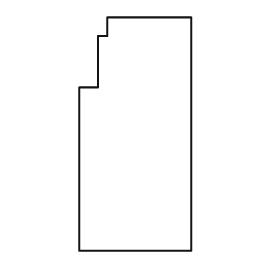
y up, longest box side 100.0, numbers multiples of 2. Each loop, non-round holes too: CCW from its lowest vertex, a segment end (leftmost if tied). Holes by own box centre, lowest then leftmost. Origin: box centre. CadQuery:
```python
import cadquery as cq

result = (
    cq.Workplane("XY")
    .moveTo(-24.0, -50.0)
    .lineTo(24.0, -50.0)
    .lineTo(24.0, 50.0)
    .lineTo(-12.0, 50.0)
    .lineTo(-12.0, 42.0)
    .lineTo(-16.0, 42.0)
    .lineTo(-16.0, 20.0)
    .lineTo(-24.0, 20.0)
    .close()
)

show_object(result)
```